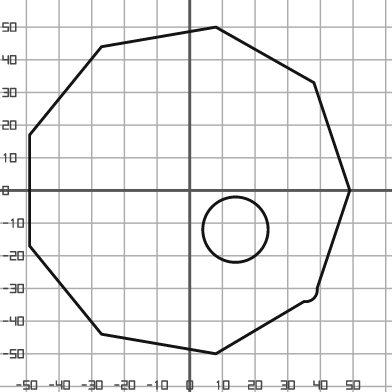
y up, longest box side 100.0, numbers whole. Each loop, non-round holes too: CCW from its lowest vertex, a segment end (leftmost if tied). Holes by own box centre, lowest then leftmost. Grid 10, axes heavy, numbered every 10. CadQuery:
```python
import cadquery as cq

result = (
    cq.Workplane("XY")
    .moveTo(8.0, -50.0)
    .lineTo(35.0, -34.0)
    .threePointArc((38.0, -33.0), (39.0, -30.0))
    .lineTo(49.0, 0.0)
    .lineTo(38.0, 33.0)
    .lineTo(8.0, 50.0)
    .lineTo(-27.0, 44.0)
    .lineTo(-49.0, 17.0)
    .lineTo(-49.0, -17.0)
    .lineTo(-27.0, -44.0)
    .close()
    .moveTo(14.0, -12.0)
    .circle(10.0)
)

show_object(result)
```